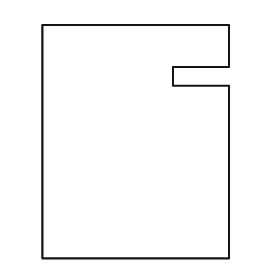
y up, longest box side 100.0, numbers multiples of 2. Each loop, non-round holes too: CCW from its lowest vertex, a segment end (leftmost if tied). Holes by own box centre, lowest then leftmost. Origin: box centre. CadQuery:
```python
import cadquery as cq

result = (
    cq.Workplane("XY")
    .moveTo(-40.0, -50.0)
    .lineTo(40.0, -50.0)
    .lineTo(40.0, 24.0)
    .lineTo(16.0, 24.0)
    .lineTo(16.0, 32.0)
    .lineTo(40.0, 32.0)
    .lineTo(40.0, 50.0)
    .lineTo(-40.0, 50.0)
    .close()
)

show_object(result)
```